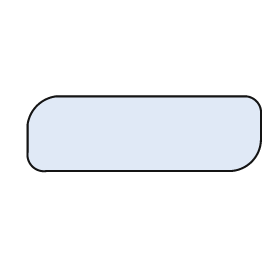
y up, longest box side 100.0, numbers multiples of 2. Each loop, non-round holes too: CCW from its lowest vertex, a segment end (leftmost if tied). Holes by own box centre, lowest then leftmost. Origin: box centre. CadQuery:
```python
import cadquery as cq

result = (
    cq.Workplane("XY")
    .moveTo(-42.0, -16.0)
    .lineTo(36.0, -16.0)
    .threePointArc((46.0, -12.0), (50.0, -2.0))
    .lineTo(50.0, 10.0)
    .threePointArc((48.0, 14.0), (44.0, 16.0))
    .lineTo(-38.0, 16.0)
    .threePointArc((-46.0, 12.0), (-50.0, 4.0))
    .lineTo(-50.0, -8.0)
    .threePointArc((-48.0, -14.0), (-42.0, -16.0))
    .close()
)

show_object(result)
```